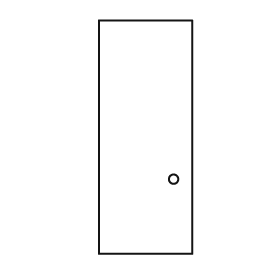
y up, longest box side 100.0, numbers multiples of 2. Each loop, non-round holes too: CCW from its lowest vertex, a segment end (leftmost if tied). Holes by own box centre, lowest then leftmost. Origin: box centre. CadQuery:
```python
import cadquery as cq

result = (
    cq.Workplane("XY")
    .moveTo(-20.0, -50.0)
    .lineTo(20.0, -50.0)
    .lineTo(20.0, 50.0)
    .lineTo(-20.0, 50.0)
    .close()
    .moveTo(12.0, -18.0)
    .circle(2.0)
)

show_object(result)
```